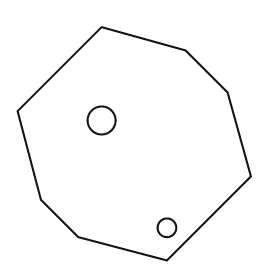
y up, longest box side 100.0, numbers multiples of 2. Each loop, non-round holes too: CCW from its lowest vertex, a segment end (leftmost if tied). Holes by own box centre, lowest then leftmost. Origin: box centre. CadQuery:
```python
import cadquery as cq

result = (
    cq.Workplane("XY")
    .moveTo(14.0, -50.0)
    .lineTo(50.0, -14.0)
    .lineTo(40.0, 22.0)
    .lineTo(22.0, 40.0)
    .lineTo(-14.0, 50.0)
    .lineTo(-50.0, 14.0)
    .lineTo(-40.0, -24.0)
    .lineTo(-24.0, -40.0)
    .close()
    .moveTo(14.0, -36.0)
    .circle(4.0)
    .moveTo(-14.0, 10.0)
    .circle(6.0)
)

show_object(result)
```